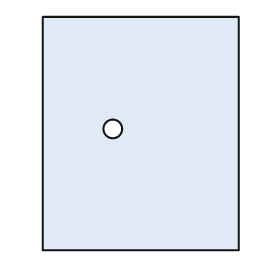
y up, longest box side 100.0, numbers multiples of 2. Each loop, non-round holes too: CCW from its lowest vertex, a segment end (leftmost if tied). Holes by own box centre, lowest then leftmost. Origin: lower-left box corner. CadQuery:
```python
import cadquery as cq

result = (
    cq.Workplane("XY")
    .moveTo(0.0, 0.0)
    .lineTo(84.0, 0.0)
    .lineTo(84.0, 100.0)
    .lineTo(0.0, 100.0)
    .close()
    .moveTo(30.0, 52.0)
    .circle(4.0)
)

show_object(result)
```